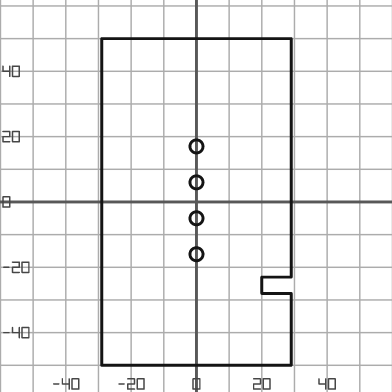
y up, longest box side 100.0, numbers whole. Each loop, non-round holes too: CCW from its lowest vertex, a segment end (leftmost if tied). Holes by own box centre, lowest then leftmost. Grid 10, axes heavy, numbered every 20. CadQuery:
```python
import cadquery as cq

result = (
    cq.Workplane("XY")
    .moveTo(-29.0, -50.0)
    .lineTo(29.0, -50.0)
    .lineTo(29.0, -28.0)
    .lineTo(20.0, -28.0)
    .lineTo(20.0, -23.0)
    .lineTo(29.0, -23.0)
    .lineTo(29.0, 50.0)
    .lineTo(-29.0, 50.0)
    .close()
    .moveTo(0.0, -16.0)
    .circle(2.0)
    .moveTo(0.0, -5.0)
    .circle(2.0)
    .moveTo(0.0, 6.0)
    .circle(2.0)
    .moveTo(0.0, 17.0)
    .circle(2.0)
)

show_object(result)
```